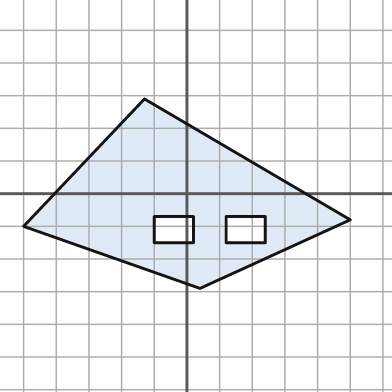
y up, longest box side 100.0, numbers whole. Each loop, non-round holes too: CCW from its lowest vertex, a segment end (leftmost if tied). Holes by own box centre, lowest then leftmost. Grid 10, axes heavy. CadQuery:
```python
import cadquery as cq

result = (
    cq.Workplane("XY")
    .moveTo(4.0, -29.0)
    .lineTo(50.0, -8.0)
    .lineTo(-13.0, 29.0)
    .lineTo(-50.0, -10.0)
    .close()
    .moveTo(-10.0, -15.0)
    .lineTo(2.0, -15.0)
    .lineTo(2.0, -7.0)
    .lineTo(-10.0, -7.0)
    .close()
    .moveTo(12.0, -15.0)
    .lineTo(24.0, -15.0)
    .lineTo(24.0, -7.0)
    .lineTo(12.0, -7.0)
    .close()
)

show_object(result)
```